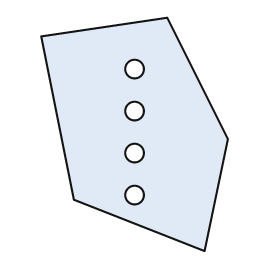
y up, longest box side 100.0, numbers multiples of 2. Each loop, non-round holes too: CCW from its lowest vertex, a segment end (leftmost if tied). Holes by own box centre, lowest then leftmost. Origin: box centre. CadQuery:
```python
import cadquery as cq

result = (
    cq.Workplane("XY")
    .moveTo(30.0, -50.0)
    .lineTo(40.0, -2.0)
    .lineTo(14.0, 50.0)
    .lineTo(-40.0, 42.0)
    .lineTo(-26.0, -28.0)
    .close()
    .moveTo(0.0, -26.0)
    .circle(4.0)
    .moveTo(0.0, -8.0)
    .circle(4.0)
    .moveTo(0.0, 10.0)
    .circle(4.0)
    .moveTo(0.0, 28.0)
    .circle(4.0)
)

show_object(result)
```